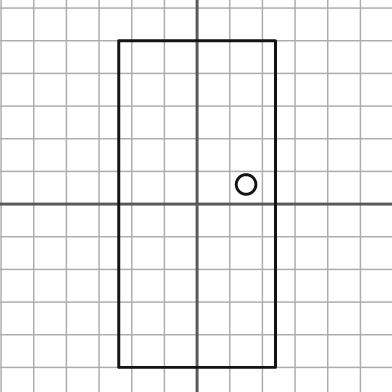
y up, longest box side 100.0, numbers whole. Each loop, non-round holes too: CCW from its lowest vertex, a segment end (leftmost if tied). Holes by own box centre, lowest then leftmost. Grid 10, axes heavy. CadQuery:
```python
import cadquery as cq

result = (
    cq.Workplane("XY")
    .moveTo(-24.0, -50.0)
    .lineTo(24.0, -50.0)
    .lineTo(24.0, 50.0)
    .lineTo(-24.0, 50.0)
    .close()
    .moveTo(15.0, 6.0)
    .circle(3.0)
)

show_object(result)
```